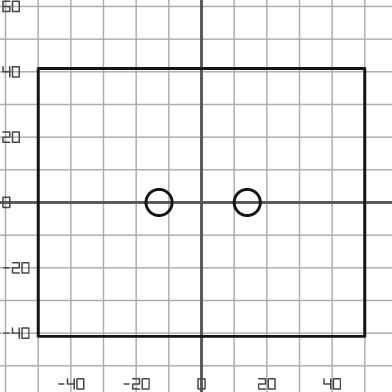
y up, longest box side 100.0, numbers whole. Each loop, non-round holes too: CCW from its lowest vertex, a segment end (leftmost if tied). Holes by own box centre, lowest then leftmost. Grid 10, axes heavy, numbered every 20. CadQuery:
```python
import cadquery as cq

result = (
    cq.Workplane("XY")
    .moveTo(-50.0, -41.0)
    .lineTo(50.0, -41.0)
    .lineTo(50.0, 41.0)
    .lineTo(-50.0, 41.0)
    .close()
    .moveTo(-13.0, 0.0)
    .circle(4.0)
    .moveTo(14.0, 0.0)
    .circle(4.0)
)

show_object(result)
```